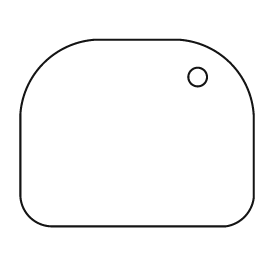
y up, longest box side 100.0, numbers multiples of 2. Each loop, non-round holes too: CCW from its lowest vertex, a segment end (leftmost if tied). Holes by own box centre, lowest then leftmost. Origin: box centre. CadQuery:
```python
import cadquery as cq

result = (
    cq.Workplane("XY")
    .moveTo(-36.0, -40.0)
    .lineTo(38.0, -40.0)
    .threePointArc((46.0, -36.0), (50.0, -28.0))
    .lineTo(50.0, 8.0)
    .threePointArc((40.0, 30.0), (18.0, 40.0))
    .lineTo(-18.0, 40.0)
    .threePointArc((-40.0, 30.0), (-50.0, 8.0))
    .lineTo(-50.0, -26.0)
    .threePointArc((-46.0, -36.0), (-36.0, -40.0))
    .close()
    .moveTo(26.0, 24.0)
    .circle(4.0)
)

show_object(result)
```